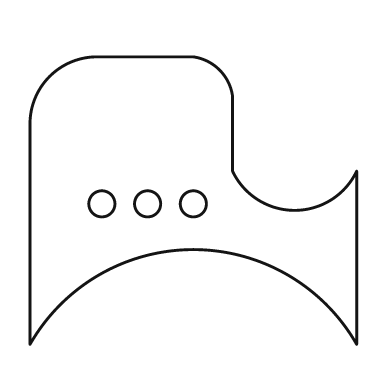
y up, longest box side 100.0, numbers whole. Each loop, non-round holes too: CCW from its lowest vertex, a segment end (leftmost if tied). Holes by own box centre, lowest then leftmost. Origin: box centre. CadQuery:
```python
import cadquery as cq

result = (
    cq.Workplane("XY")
    .moveTo(-50.0, -44.0)
    .threePointArc((0.0, -15.0), (50.0, -44.0))
    .lineTo(50.0, 9.0)
    .threePointArc((31.0, -3.0), (12.0, 9.0))
    .lineTo(12.0, 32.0)
    .threePointArc((8.0, 40.0), (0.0, 44.0))
    .lineTo(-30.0, 44.0)
    .threePointArc((-44.0, 38.0), (-50.0, 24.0))
    .close()
    .moveTo(-28.0, -1.0)
    .circle(4.0)
    .moveTo(-14.0, -1.0)
    .circle(4.0)
    .moveTo(0.0, -1.0)
    .circle(4.0)
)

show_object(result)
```